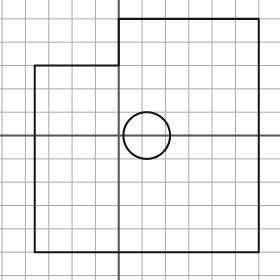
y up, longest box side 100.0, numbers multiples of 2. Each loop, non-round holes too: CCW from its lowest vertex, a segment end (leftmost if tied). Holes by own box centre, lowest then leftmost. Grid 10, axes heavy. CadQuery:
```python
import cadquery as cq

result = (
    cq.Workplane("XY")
    .moveTo(-36.0, -50.0)
    .lineTo(60.0, -50.0)
    .lineTo(60.0, 50.0)
    .lineTo(0.0, 50.0)
    .lineTo(0.0, 30.0)
    .lineTo(-36.0, 30.0)
    .close()
    .moveTo(12.0, 0.0)
    .circle(10.0)
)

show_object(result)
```